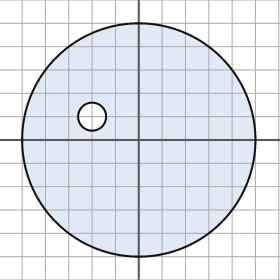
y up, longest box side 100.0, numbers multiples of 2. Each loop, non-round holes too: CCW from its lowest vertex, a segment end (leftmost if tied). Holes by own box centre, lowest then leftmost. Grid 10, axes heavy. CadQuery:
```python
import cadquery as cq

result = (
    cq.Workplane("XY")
    .moveTo(0.0, 0.0)
    .circle(50.0)
    .moveTo(-20.0, 10.0)
    .circle(6.0)
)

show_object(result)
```